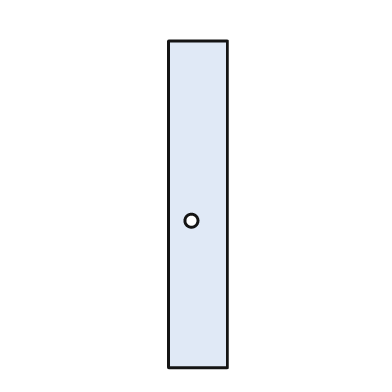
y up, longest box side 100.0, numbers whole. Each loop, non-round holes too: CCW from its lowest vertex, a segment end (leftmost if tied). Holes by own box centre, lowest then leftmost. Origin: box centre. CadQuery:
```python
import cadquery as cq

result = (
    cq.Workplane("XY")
    .moveTo(-9.0, -50.0)
    .lineTo(9.0, -50.0)
    .lineTo(9.0, 50.0)
    .lineTo(-9.0, 50.0)
    .close()
    .moveTo(-2.0, -5.0)
    .circle(2.0)
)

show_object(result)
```